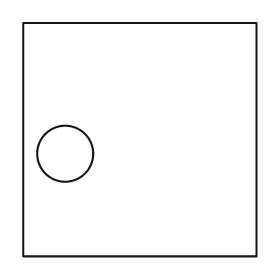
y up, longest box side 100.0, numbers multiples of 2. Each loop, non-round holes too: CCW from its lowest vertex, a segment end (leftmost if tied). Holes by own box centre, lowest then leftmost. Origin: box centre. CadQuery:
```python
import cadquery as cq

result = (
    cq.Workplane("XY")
    .moveTo(-50.0, -50.0)
    .lineTo(50.0, -50.0)
    .lineTo(50.0, 50.0)
    .lineTo(-50.0, 50.0)
    .close()
    .moveTo(-32.0, -6.0)
    .circle(12.0)
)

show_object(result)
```